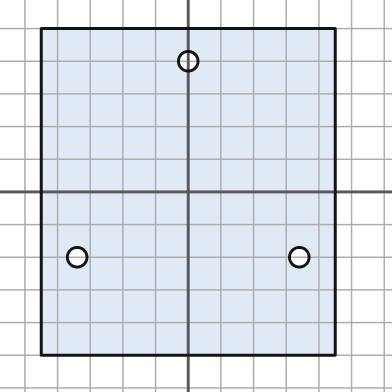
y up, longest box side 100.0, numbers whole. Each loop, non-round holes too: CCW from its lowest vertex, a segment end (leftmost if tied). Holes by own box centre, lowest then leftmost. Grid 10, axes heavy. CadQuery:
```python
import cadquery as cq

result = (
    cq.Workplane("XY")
    .moveTo(-45.0, -50.0)
    .lineTo(45.0, -50.0)
    .lineTo(45.0, 50.0)
    .lineTo(-45.0, 50.0)
    .close()
    .moveTo(-34.0, -20.0)
    .circle(3.0)
    .moveTo(34.0, -20.0)
    .circle(3.0)
    .moveTo(0.0, 40.0)
    .circle(3.0)
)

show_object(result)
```